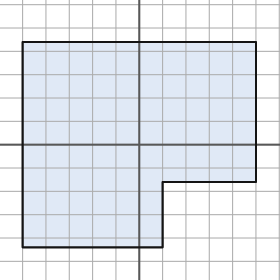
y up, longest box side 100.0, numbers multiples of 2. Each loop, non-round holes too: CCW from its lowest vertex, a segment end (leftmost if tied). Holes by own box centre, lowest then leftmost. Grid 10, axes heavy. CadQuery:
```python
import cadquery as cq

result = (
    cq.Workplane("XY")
    .moveTo(-50.0, -44.0)
    .lineTo(10.0, -44.0)
    .lineTo(10.0, -16.0)
    .lineTo(50.0, -16.0)
    .lineTo(50.0, 44.0)
    .lineTo(-50.0, 44.0)
    .close()
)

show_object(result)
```